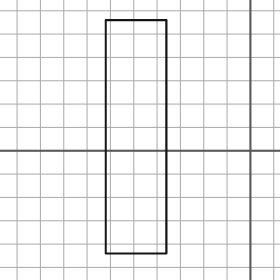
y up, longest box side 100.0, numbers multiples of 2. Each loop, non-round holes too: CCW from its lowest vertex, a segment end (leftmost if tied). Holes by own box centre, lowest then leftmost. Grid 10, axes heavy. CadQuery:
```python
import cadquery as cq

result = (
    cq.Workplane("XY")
    .moveTo(-62.0, -44.0)
    .lineTo(-36.0, -44.0)
    .lineTo(-36.0, 56.0)
    .lineTo(-62.0, 56.0)
    .close()
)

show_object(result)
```